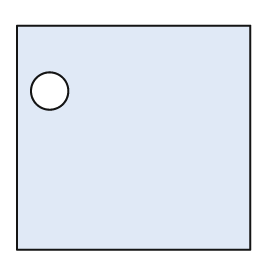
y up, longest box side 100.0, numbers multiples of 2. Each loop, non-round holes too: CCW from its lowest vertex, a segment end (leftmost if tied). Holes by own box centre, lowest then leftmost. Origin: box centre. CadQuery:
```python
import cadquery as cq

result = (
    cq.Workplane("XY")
    .moveTo(-50.0, -48.0)
    .lineTo(50.0, -48.0)
    .lineTo(50.0, 48.0)
    .lineTo(-50.0, 48.0)
    .close()
    .moveTo(-36.0, 20.0)
    .circle(8.0)
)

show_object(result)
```